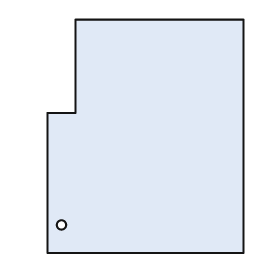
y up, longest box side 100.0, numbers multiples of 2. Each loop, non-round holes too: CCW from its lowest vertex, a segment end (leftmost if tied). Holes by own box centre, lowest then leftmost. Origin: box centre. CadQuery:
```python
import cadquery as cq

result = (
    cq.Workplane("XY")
    .moveTo(-42.0, -50.0)
    .lineTo(42.0, -50.0)
    .lineTo(42.0, 50.0)
    .lineTo(-30.0, 50.0)
    .lineTo(-30.0, 10.0)
    .lineTo(-42.0, 10.0)
    .close()
    .moveTo(-36.0, -38.0)
    .circle(2.0)
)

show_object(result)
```